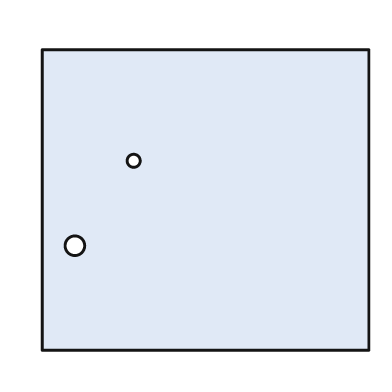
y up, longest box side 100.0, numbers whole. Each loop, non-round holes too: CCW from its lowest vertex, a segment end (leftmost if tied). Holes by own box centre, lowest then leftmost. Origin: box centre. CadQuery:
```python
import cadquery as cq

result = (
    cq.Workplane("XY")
    .moveTo(-50.0, -46.0)
    .lineTo(50.0, -46.0)
    .lineTo(50.0, 46.0)
    .lineTo(-50.0, 46.0)
    .close()
    .moveTo(-40.0, -14.0)
    .circle(3.0)
    .moveTo(-22.0, 12.0)
    .circle(2.0)
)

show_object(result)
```